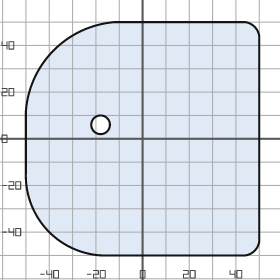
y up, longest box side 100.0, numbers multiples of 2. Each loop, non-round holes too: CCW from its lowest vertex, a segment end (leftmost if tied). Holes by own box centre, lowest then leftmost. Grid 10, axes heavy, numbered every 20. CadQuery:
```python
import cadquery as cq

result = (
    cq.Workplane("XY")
    .moveTo(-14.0, -50.0)
    .lineTo(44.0, -50.0)
    .threePointArc((48.0, -48.0), (50.0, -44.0))
    .lineTo(50.0, 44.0)
    .threePointArc((48.0, 48.0), (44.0, 50.0))
    .lineTo(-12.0, 50.0)
    .threePointArc((-38.0, 38.0), (-50.0, 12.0))
    .lineTo(-50.0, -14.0)
    .threePointArc((-40.0, -40.0), (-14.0, -50.0))
    .close()
    .moveTo(-18.0, 6.0)
    .circle(4.0)
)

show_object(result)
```